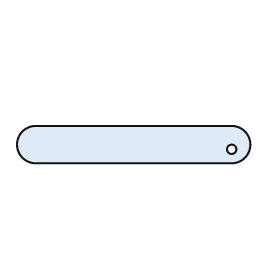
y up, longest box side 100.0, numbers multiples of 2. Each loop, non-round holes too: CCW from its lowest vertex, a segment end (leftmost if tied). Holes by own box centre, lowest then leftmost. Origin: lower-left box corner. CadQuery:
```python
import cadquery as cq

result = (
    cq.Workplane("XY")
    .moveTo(8.0, 0.0)
    .lineTo(92.0, 0.0)
    .threePointArc((100.0, 8.0), (92.0, 16.0))
    .lineTo(8.0, 16.0)
    .threePointArc((0.0, 8.0), (8.0, 0.0))
    .close()
    .moveTo(92.0, 6.0)
    .circle(2.0)
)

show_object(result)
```